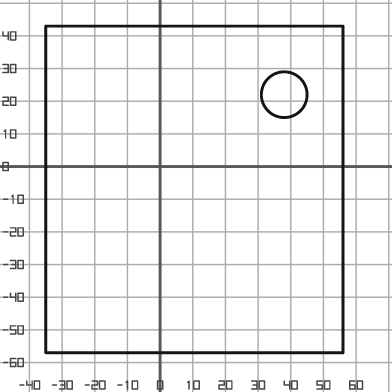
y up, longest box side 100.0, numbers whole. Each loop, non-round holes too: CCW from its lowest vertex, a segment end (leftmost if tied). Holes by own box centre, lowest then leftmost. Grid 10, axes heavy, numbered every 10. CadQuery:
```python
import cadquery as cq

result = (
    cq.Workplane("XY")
    .moveTo(-35.0, -57.0)
    .lineTo(56.0, -57.0)
    .lineTo(56.0, 43.0)
    .lineTo(-35.0, 43.0)
    .close()
    .moveTo(38.0, 22.0)
    .circle(7.0)
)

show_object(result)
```